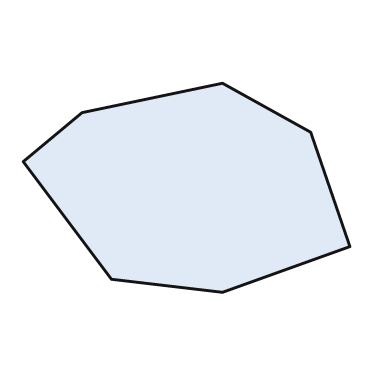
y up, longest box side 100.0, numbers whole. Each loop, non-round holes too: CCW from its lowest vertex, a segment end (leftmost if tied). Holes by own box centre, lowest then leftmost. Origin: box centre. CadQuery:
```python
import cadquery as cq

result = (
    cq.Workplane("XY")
    .moveTo(11.0, -32.0)
    .lineTo(50.0, -18.0)
    .lineTo(38.0, 17.0)
    .lineTo(11.0, 32.0)
    .lineTo(-32.0, 23.0)
    .lineTo(-50.0, 8.0)
    .lineTo(-23.0, -28.0)
    .close()
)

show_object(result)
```